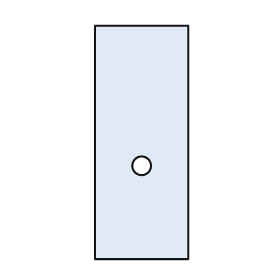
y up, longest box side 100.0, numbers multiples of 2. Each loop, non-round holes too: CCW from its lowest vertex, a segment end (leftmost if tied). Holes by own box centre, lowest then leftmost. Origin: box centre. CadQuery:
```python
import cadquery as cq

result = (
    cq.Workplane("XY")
    .moveTo(-20.0, -50.0)
    .lineTo(20.0, -50.0)
    .lineTo(20.0, 50.0)
    .lineTo(-20.0, 50.0)
    .close()
    .moveTo(0.0, -10.0)
    .circle(4.0)
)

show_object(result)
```